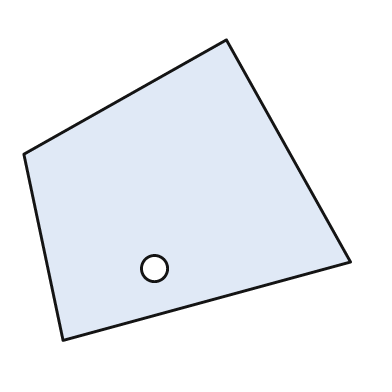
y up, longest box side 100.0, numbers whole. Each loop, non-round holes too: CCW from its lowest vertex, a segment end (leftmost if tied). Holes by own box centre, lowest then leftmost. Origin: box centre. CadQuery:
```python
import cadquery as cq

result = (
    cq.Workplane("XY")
    .moveTo(-38.0, -46.0)
    .lineTo(50.0, -22.0)
    .lineTo(12.0, 46.0)
    .lineTo(-50.0, 11.0)
    .close()
    .moveTo(-10.0, -24.0)
    .circle(4.0)
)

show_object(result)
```